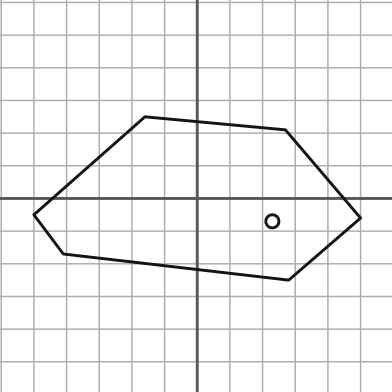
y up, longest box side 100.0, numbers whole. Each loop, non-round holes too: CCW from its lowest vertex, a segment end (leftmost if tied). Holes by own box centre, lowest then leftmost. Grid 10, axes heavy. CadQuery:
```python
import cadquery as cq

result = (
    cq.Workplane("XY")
    .moveTo(28.0, -25.0)
    .lineTo(50.0, -6.0)
    .lineTo(27.0, 21.0)
    .lineTo(-16.0, 25.0)
    .lineTo(-50.0, -5.0)
    .lineTo(-41.0, -17.0)
    .close()
    .moveTo(23.0, -7.0)
    .circle(2.0)
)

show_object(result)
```